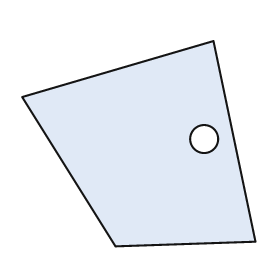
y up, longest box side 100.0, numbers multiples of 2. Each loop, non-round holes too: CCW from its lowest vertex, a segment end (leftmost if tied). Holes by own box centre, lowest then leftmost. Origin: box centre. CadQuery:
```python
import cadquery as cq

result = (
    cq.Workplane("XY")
    .moveTo(-10.0, -44.0)
    .lineTo(50.0, -42.0)
    .lineTo(32.0, 44.0)
    .lineTo(-50.0, 20.0)
    .close()
    .moveTo(28.0, 2.0)
    .circle(6.0)
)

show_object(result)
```